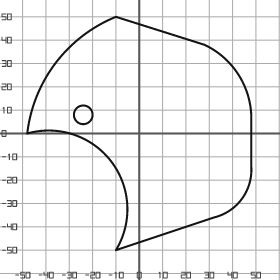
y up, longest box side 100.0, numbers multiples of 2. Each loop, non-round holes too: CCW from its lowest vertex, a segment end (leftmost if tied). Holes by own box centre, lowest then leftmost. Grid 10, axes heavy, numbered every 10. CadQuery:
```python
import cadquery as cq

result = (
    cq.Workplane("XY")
    .moveTo(-10.0, -50.0)
    .lineTo(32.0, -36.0)
    .threePointArc((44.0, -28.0), (48.0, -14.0))
    .lineTo(48.0, 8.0)
    .threePointArc((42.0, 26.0), (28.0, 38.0))
    .lineTo(-10.0, 50.0)
    .threePointArc((-36.0, 30.0), (-48.0, 0.0))
    .threePointArc((-12.0, -12.0), (-10.0, -50.0))
    .close()
    .moveTo(-24.0, 8.0)
    .circle(4.0)
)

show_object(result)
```